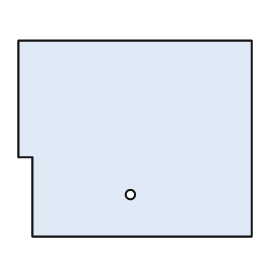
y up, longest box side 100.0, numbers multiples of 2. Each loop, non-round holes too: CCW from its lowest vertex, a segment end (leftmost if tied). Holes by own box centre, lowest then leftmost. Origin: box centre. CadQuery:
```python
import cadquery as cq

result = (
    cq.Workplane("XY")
    .moveTo(-44.0, -42.0)
    .lineTo(50.0, -42.0)
    .lineTo(50.0, 42.0)
    .lineTo(-50.0, 42.0)
    .lineTo(-50.0, -8.0)
    .lineTo(-44.0, -8.0)
    .close()
    .moveTo(-2.0, -24.0)
    .circle(2.0)
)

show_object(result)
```